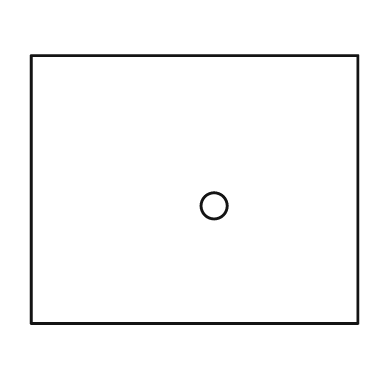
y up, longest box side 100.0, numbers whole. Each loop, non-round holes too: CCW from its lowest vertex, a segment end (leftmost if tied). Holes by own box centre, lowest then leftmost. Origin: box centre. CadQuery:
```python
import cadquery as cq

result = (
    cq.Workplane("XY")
    .moveTo(-50.0, -41.0)
    .lineTo(50.0, -41.0)
    .lineTo(50.0, 41.0)
    .lineTo(-50.0, 41.0)
    .close()
    .moveTo(6.0, -5.0)
    .circle(4.0)
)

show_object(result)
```